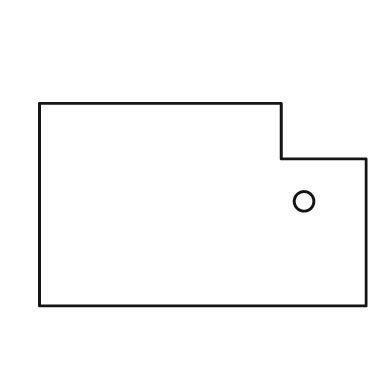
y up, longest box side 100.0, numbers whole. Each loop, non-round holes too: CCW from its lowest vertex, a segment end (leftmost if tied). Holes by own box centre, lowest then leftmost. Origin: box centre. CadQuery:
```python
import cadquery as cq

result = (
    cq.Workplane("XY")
    .moveTo(-50.0, -31.0)
    .lineTo(50.0, -31.0)
    .lineTo(50.0, 14.0)
    .lineTo(24.0, 14.0)
    .lineTo(24.0, 31.0)
    .lineTo(-50.0, 31.0)
    .close()
    .moveTo(31.0, 1.0)
    .circle(3.0)
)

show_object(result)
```